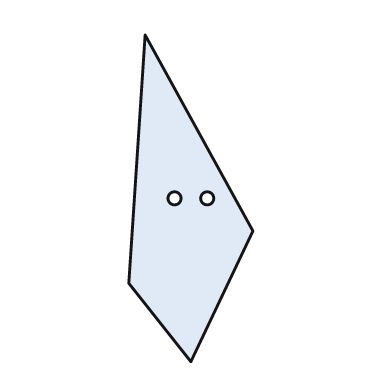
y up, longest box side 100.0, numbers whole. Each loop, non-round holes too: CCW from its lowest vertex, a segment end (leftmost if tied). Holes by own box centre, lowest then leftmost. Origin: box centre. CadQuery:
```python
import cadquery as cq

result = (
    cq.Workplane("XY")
    .moveTo(0.0, -50.0)
    .lineTo(19.0, -10.0)
    .lineTo(-14.0, 50.0)
    .lineTo(-19.0, -26.0)
    .close()
    .moveTo(-5.0, 0.0)
    .circle(2.0)
    .moveTo(5.0, 0.0)
    .circle(2.0)
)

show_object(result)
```